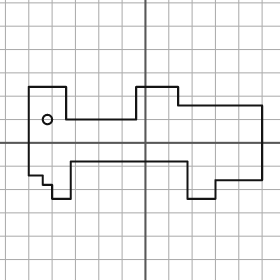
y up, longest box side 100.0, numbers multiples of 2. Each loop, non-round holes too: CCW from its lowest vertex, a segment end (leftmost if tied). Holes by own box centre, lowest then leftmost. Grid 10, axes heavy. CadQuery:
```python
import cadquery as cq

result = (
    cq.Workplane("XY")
    .moveTo(-40.0, -24.0)
    .lineTo(-32.0, -24.0)
    .lineTo(-32.0, -8.0)
    .lineTo(18.0, -8.0)
    .lineTo(18.0, -24.0)
    .lineTo(30.0, -24.0)
    .lineTo(30.0, -16.0)
    .lineTo(50.0, -16.0)
    .lineTo(50.0, 16.0)
    .lineTo(14.0, 16.0)
    .lineTo(14.0, 24.0)
    .lineTo(-4.0, 24.0)
    .lineTo(-4.0, 10.0)
    .lineTo(-34.0, 10.0)
    .lineTo(-34.0, 24.0)
    .lineTo(-50.0, 24.0)
    .lineTo(-50.0, -14.0)
    .lineTo(-44.0, -14.0)
    .lineTo(-44.0, -18.0)
    .lineTo(-40.0, -18.0)
    .close()
    .moveTo(-42.0, 10.0)
    .circle(2.0)
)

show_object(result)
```